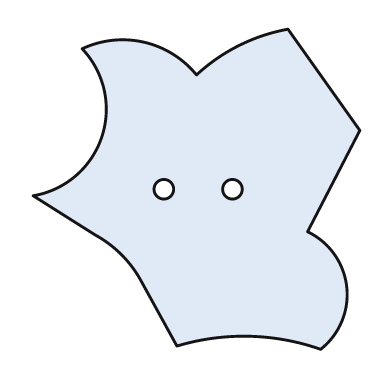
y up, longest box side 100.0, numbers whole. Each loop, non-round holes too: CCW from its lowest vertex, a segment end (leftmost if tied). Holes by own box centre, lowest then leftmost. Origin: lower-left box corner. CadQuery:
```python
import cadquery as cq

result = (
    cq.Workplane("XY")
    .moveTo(88.0, 0.0)
    .threePointArc((96.0, 19.0), (84.0, 36.0))
    .lineTo(100.0, 67.0)
    .lineTo(78.0, 98.0)
    .threePointArc((63.0, 93.0), (50.0, 84.0))
    .threePointArc((34.0, 94.0), (15.0, 92.0))
    .threePointArc((21.0, 65.0), (0.0, 47.0))
    .lineTo(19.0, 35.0)
    .threePointArc((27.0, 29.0), (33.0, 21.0))
    .lineTo(44.0, 1.0)
    .threePointArc((66.0, 4.0), (88.0, 0.0))
    .close()
    .moveTo(40.0, 49.0)
    .circle(3.0)
    .moveTo(61.0, 49.0)
    .circle(3.0)
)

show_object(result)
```